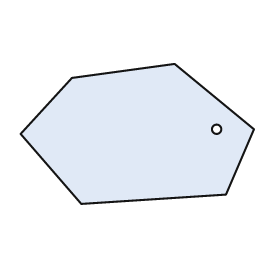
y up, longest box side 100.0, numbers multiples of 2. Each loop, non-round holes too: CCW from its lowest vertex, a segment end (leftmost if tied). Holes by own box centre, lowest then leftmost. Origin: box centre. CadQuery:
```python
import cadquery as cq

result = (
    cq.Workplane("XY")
    .moveTo(-24.0, -30.0)
    .lineTo(38.0, -26.0)
    .lineTo(50.0, 2.0)
    .lineTo(16.0, 30.0)
    .lineTo(-28.0, 24.0)
    .lineTo(-50.0, 0.0)
    .close()
    .moveTo(34.0, 2.0)
    .circle(2.0)
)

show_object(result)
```